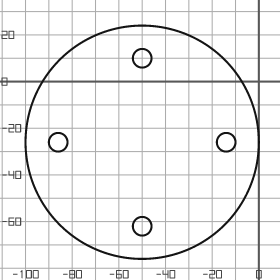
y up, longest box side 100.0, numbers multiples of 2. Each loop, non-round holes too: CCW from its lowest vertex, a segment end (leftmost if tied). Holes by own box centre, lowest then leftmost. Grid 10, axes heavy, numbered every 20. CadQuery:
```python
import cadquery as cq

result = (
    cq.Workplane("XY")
    .moveTo(-50.0, -26.0)
    .circle(50.0)
    .moveTo(-50.0, -62.0)
    .circle(4.0)
    .moveTo(-86.0, -26.0)
    .circle(4.0)
    .moveTo(-14.0, -26.0)
    .circle(4.0)
    .moveTo(-50.0, 10.0)
    .circle(4.0)
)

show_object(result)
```